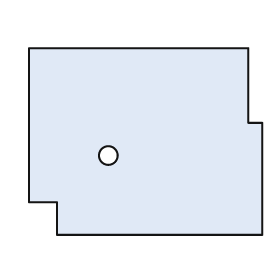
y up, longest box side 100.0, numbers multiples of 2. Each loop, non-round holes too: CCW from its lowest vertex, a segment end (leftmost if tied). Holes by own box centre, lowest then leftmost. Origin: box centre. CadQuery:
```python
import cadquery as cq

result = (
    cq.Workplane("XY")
    .moveTo(-38.0, -40.0)
    .lineTo(50.0, -40.0)
    .lineTo(50.0, 8.0)
    .lineTo(44.0, 8.0)
    .lineTo(44.0, 40.0)
    .lineTo(-50.0, 40.0)
    .lineTo(-50.0, -26.0)
    .lineTo(-38.0, -26.0)
    .close()
    .moveTo(-16.0, -6.0)
    .circle(4.0)
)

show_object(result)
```